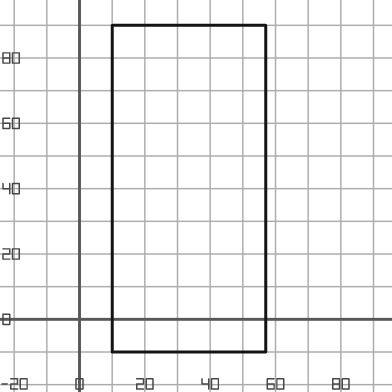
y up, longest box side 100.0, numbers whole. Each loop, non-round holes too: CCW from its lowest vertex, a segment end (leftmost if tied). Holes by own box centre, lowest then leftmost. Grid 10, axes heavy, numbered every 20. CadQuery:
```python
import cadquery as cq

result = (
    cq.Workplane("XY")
    .moveTo(10.0, -10.0)
    .lineTo(57.0, -10.0)
    .lineTo(57.0, 90.0)
    .lineTo(10.0, 90.0)
    .close()
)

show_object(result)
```